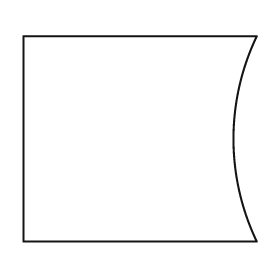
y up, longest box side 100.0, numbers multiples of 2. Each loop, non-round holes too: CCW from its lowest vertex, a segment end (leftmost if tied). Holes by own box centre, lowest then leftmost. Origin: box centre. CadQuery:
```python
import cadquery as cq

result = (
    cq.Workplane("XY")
    .moveTo(-50.0, -44.0)
    .lineTo(50.0, -44.0)
    .threePointArc((40.0, 0.0), (50.0, 44.0))
    .lineTo(-50.0, 44.0)
    .close()
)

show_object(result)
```